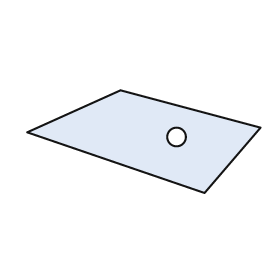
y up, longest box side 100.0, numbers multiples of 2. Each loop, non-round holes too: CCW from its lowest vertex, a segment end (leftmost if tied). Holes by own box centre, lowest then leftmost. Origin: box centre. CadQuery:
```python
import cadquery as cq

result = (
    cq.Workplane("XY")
    .moveTo(26.0, -22.0)
    .lineTo(50.0, 6.0)
    .lineTo(-10.0, 22.0)
    .lineTo(-50.0, 4.0)
    .close()
    .moveTo(14.0, 2.0)
    .circle(4.0)
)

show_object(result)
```